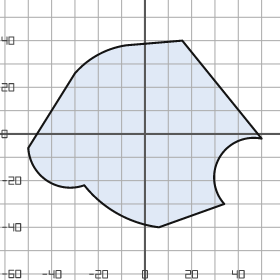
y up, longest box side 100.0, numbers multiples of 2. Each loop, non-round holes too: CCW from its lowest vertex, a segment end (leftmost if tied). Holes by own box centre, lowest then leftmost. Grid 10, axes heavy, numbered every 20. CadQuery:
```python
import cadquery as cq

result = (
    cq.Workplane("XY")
    .moveTo(6.0, -40.0)
    .lineTo(34.0, -30.0)
    .threePointArc((32.0, -10.0), (50.0, -2.0))
    .lineTo(16.0, 40.0)
    .lineTo(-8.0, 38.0)
    .threePointArc((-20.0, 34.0), (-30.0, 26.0))
    .lineTo(-50.0, -6.0)
    .threePointArc((-42.0, -20.0), (-26.0, -22.0))
    .threePointArc((-12.0, -34.0), (6.0, -40.0))
    .close()
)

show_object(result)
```